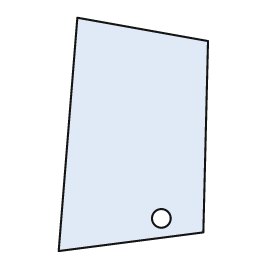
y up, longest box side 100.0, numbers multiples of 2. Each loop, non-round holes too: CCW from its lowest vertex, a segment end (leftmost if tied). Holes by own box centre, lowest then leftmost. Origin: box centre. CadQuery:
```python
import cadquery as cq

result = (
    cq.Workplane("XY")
    .moveTo(-32.0, -50.0)
    .lineTo(30.0, -42.0)
    .lineTo(32.0, 40.0)
    .lineTo(-24.0, 50.0)
    .close()
    .moveTo(12.0, -36.0)
    .circle(4.0)
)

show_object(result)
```